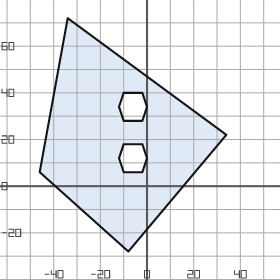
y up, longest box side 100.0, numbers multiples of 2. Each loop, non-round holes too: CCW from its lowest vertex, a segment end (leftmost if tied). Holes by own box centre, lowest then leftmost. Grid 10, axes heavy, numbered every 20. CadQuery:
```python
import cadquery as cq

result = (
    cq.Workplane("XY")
    .moveTo(-8.0, -28.0)
    .lineTo(34.0, 22.0)
    .lineTo(-34.0, 72.0)
    .lineTo(-46.0, 6.0)
    .close()
    .moveTo(-10.0, 6.0)
    .lineTo(-2.0, 6.0)
    .lineTo(0.0, 12.0)
    .lineTo(-2.0, 18.0)
    .lineTo(-10.0, 18.0)
    .lineTo(-12.0, 12.0)
    .close()
    .moveTo(-10.0, 28.0)
    .lineTo(-2.0, 28.0)
    .lineTo(0.0, 34.0)
    .lineTo(-2.0, 40.0)
    .lineTo(-10.0, 40.0)
    .lineTo(-12.0, 34.0)
    .close()
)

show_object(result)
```